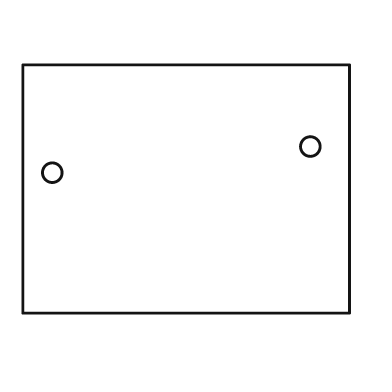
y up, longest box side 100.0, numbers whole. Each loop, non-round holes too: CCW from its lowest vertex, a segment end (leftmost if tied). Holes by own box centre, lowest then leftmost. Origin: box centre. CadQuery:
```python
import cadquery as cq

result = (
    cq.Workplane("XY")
    .moveTo(-50.0, -38.0)
    .lineTo(50.0, -38.0)
    .lineTo(50.0, 38.0)
    .lineTo(-50.0, 38.0)
    .close()
    .moveTo(-41.0, 5.0)
    .circle(3.0)
    .moveTo(38.0, 13.0)
    .circle(3.0)
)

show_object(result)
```